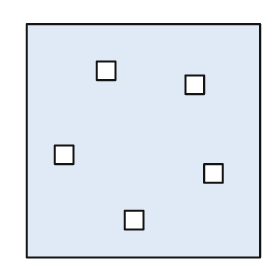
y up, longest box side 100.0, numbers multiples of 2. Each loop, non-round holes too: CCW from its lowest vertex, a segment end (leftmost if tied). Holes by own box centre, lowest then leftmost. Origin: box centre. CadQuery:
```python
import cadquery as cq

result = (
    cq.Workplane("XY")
    .moveTo(-50.0, -50.0)
    .lineTo(50.0, -50.0)
    .lineTo(50.0, 50.0)
    .lineTo(-50.0, 50.0)
    .close()
    .moveTo(-8.0, -38.0)
    .lineTo(0.0, -38.0)
    .lineTo(0.0, -30.0)
    .lineTo(-8.0, -30.0)
    .close()
    .moveTo(26.0, -18.0)
    .lineTo(34.0, -18.0)
    .lineTo(34.0, -10.0)
    .lineTo(26.0, -10.0)
    .close()
    .moveTo(-38.0, -10.0)
    .lineTo(-30.0, -10.0)
    .lineTo(-30.0, -2.0)
    .lineTo(-38.0, -2.0)
    .close()
    .moveTo(18.0, 20.0)
    .lineTo(26.0, 20.0)
    .lineTo(26.0, 28.0)
    .lineTo(18.0, 28.0)
    .close()
    .moveTo(-20.0, 26.0)
    .lineTo(-12.0, 26.0)
    .lineTo(-12.0, 34.0)
    .lineTo(-20.0, 34.0)
    .close()
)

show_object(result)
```